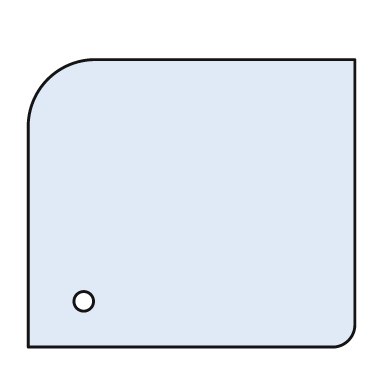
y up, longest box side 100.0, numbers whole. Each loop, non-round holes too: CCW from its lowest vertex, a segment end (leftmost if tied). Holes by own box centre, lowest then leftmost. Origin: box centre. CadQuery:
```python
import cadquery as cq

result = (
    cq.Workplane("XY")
    .moveTo(-50.0, -44.0)
    .lineTo(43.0, -44.0)
    .threePointArc((48.0, -42.0), (50.0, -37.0))
    .lineTo(50.0, 44.0)
    .lineTo(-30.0, 44.0)
    .threePointArc((-44.0, 38.0), (-50.0, 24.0))
    .close()
    .moveTo(-33.0, -30.0)
    .circle(3.0)
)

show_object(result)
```